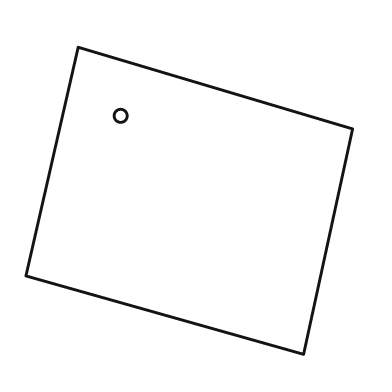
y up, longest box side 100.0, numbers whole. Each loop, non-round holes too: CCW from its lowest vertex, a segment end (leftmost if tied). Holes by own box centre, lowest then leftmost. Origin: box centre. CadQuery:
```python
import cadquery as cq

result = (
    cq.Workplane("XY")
    .moveTo(35.0, -47.0)
    .lineTo(50.0, 22.0)
    .lineTo(-34.0, 47.0)
    .lineTo(-50.0, -23.0)
    .close()
    .moveTo(-21.0, 26.0)
    .circle(2.0)
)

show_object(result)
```